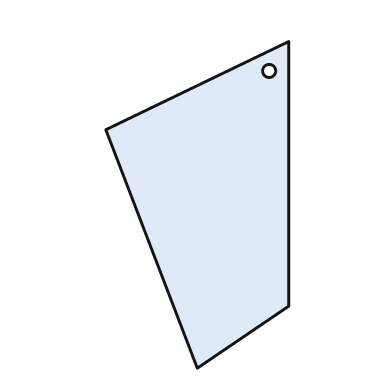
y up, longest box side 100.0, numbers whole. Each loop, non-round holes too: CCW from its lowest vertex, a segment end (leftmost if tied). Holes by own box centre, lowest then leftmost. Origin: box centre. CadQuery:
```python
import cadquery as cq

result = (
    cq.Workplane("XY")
    .moveTo(0.0, -50.0)
    .lineTo(28.0, -31.0)
    .lineTo(28.0, 50.0)
    .lineTo(-28.0, 23.0)
    .close()
    .moveTo(22.0, 41.0)
    .circle(2.0)
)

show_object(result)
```